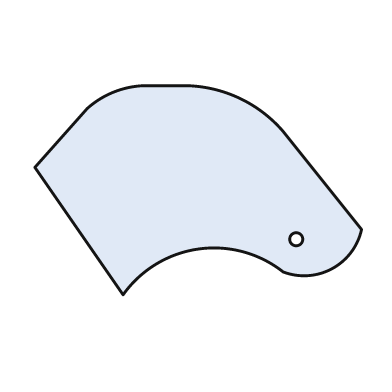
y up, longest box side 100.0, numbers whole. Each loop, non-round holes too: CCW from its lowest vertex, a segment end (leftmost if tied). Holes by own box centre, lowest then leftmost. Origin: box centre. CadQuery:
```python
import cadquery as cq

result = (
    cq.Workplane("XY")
    .moveTo(-23.0, -32.0)
    .threePointArc((0.0, -18.0), (26.0, -25.0))
    .threePointArc((41.0, -24.0), (50.0, -12.0))
    .lineTo(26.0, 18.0)
    .threePointArc((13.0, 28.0), (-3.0, 32.0))
    .lineTo(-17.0, 32.0)
    .threePointArc((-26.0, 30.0), (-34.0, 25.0))
    .lineTo(-50.0, 7.0)
    .close()
    .moveTo(30.0, -15.0)
    .circle(2.0)
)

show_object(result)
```